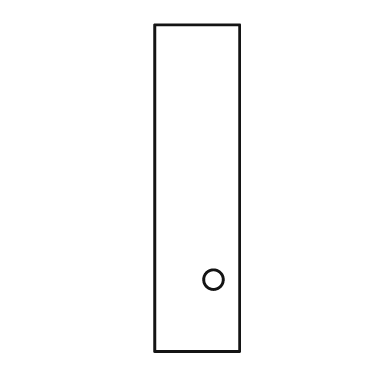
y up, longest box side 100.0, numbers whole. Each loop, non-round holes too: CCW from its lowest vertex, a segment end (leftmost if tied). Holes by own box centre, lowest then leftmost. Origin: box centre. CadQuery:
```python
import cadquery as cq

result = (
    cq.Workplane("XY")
    .moveTo(-13.0, -50.0)
    .lineTo(13.0, -50.0)
    .lineTo(13.0, 50.0)
    .lineTo(-13.0, 50.0)
    .close()
    .moveTo(5.0, -28.0)
    .circle(3.0)
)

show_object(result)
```